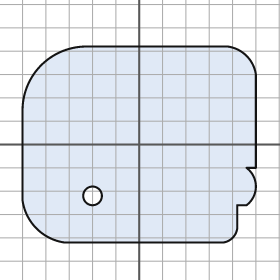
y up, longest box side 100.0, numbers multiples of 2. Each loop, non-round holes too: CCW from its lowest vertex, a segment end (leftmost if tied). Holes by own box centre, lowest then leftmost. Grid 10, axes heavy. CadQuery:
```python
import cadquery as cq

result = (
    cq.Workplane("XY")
    .moveTo(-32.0, -42.0)
    .lineTo(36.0, -42.0)
    .threePointArc((40.0, -40.0), (42.0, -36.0))
    .lineTo(42.0, -26.0)
    .lineTo(46.0, -26.0)
    .threePointArc((50.0, -18.0), (46.0, -10.0))
    .lineTo(50.0, -10.0)
    .lineTo(50.0, 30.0)
    .threePointArc((46.0, 38.0), (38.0, 42.0))
    .lineTo(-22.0, 42.0)
    .threePointArc((-42.0, 34.0), (-50.0, 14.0))
    .lineTo(-50.0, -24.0)
    .threePointArc((-44.0, -36.0), (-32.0, -42.0))
    .close()
    .moveTo(-20.0, -22.0)
    .circle(4.0)
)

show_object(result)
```